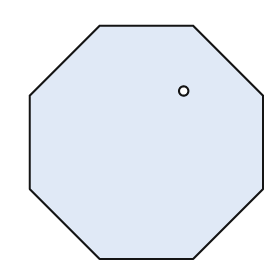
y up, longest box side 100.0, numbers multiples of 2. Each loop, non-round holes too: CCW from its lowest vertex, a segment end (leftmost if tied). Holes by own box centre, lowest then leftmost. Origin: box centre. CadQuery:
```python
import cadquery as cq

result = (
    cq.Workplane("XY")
    .moveTo(-20.0, -50.0)
    .lineTo(20.0, -50.0)
    .lineTo(50.0, -20.0)
    .lineTo(50.0, 20.0)
    .lineTo(20.0, 50.0)
    .lineTo(-20.0, 50.0)
    .lineTo(-50.0, 20.0)
    .lineTo(-50.0, -20.0)
    .close()
    .moveTo(16.0, 22.0)
    .circle(2.0)
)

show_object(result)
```